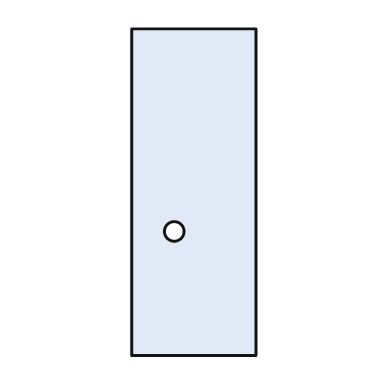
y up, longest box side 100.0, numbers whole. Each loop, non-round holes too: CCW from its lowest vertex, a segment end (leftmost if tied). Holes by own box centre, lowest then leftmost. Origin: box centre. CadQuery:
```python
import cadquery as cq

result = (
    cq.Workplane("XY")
    .moveTo(-19.0, -50.0)
    .lineTo(19.0, -50.0)
    .lineTo(19.0, 50.0)
    .lineTo(-19.0, 50.0)
    .close()
    .moveTo(-6.0, -12.0)
    .circle(3.0)
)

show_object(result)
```